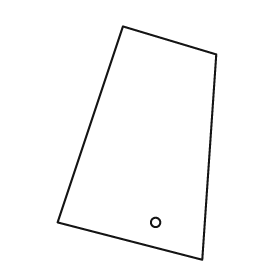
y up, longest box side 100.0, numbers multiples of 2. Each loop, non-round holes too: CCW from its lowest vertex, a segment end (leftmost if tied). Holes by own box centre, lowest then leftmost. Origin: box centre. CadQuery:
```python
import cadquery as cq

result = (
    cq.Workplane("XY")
    .moveTo(28.0, -50.0)
    .lineTo(34.0, 38.0)
    .lineTo(-6.0, 50.0)
    .lineTo(-34.0, -34.0)
    .close()
    .moveTo(8.0, -34.0)
    .circle(2.0)
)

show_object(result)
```